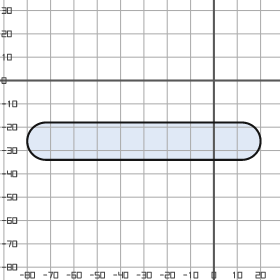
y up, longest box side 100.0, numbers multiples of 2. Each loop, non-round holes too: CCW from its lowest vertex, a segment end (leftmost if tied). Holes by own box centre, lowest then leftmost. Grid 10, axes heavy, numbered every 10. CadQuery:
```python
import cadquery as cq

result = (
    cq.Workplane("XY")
    .moveTo(-72.0, -34.0)
    .lineTo(12.0, -34.0)
    .threePointArc((20.0, -26.0), (12.0, -18.0))
    .lineTo(-72.0, -18.0)
    .threePointArc((-80.0, -26.0), (-72.0, -34.0))
    .close()
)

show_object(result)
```